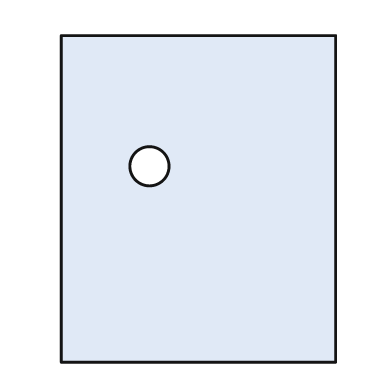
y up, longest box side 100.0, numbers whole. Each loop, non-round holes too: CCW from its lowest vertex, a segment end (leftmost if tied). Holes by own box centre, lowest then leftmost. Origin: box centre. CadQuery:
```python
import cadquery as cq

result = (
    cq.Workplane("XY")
    .moveTo(-42.0, -50.0)
    .lineTo(42.0, -50.0)
    .lineTo(42.0, 50.0)
    .lineTo(-42.0, 50.0)
    .close()
    .moveTo(-15.0, 10.0)
    .circle(6.0)
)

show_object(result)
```